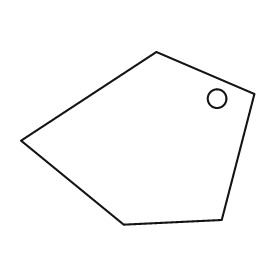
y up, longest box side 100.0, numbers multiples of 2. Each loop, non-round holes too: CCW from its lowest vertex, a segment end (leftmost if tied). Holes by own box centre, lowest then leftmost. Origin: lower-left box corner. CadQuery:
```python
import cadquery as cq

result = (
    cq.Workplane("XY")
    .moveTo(44.0, 0.0)
    .lineTo(86.0, 2.0)
    .lineTo(100.0, 56.0)
    .lineTo(58.0, 74.0)
    .lineTo(0.0, 36.0)
    .close()
    .moveTo(84.0, 54.0)
    .circle(4.0)
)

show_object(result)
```